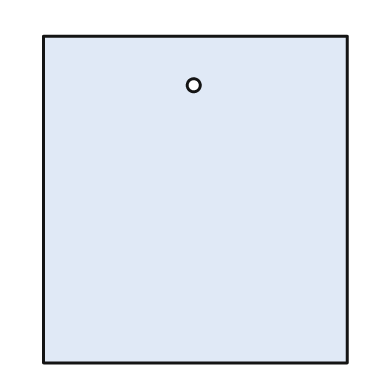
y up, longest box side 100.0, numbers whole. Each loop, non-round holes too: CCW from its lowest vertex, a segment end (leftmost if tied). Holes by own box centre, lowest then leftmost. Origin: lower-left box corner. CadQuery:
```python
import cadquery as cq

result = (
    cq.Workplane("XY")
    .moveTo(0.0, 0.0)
    .lineTo(93.0, 0.0)
    .lineTo(93.0, 100.0)
    .lineTo(0.0, 100.0)
    .close()
    .moveTo(46.0, 85.0)
    .circle(2.0)
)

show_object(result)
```